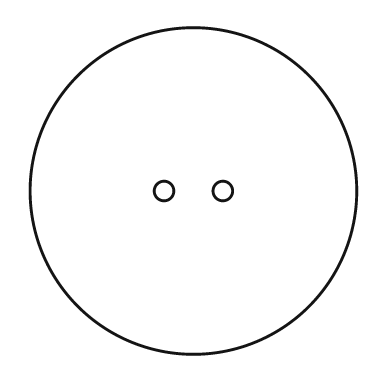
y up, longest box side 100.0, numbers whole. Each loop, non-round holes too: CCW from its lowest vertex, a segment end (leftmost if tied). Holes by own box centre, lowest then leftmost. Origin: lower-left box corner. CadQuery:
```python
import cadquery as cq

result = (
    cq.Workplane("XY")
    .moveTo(50.0, 50.0)
    .circle(50.0)
    .moveTo(41.0, 50.0)
    .circle(3.0)
    .moveTo(59.0, 50.0)
    .circle(3.0)
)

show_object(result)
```